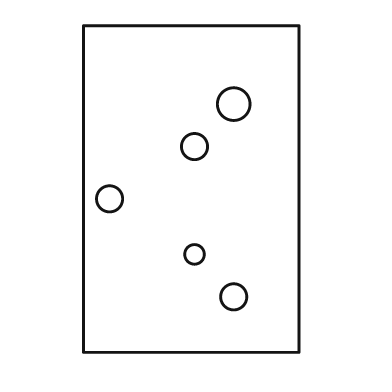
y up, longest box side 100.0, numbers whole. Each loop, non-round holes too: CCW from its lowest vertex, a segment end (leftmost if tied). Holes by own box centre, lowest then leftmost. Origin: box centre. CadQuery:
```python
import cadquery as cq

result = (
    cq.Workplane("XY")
    .moveTo(-33.0, -50.0)
    .lineTo(33.0, -50.0)
    .lineTo(33.0, 50.0)
    .lineTo(-33.0, 50.0)
    .close()
    .moveTo(13.0, -33.0)
    .circle(4.0)
    .moveTo(1.0, -20.0)
    .circle(3.0)
    .moveTo(-25.0, -3.0)
    .circle(4.0)
    .moveTo(1.0, 13.0)
    .circle(4.0)
    .moveTo(13.0, 26.0)
    .circle(5.0)
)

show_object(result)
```